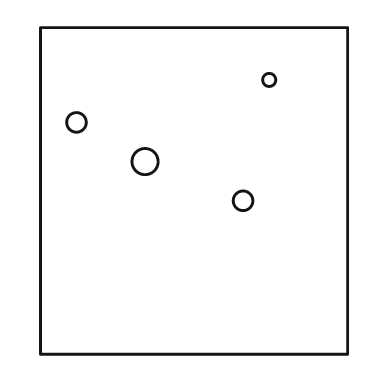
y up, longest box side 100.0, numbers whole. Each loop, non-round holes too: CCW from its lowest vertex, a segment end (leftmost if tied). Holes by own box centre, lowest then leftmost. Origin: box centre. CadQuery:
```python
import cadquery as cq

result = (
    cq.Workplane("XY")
    .moveTo(-47.0, -50.0)
    .lineTo(47.0, -50.0)
    .lineTo(47.0, 50.0)
    .lineTo(-47.0, 50.0)
    .close()
    .moveTo(15.0, -3.0)
    .circle(3.0)
    .moveTo(-15.0, 9.0)
    .circle(4.0)
    .moveTo(-36.0, 21.0)
    .circle(3.0)
    .moveTo(23.0, 34.0)
    .circle(2.0)
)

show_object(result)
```